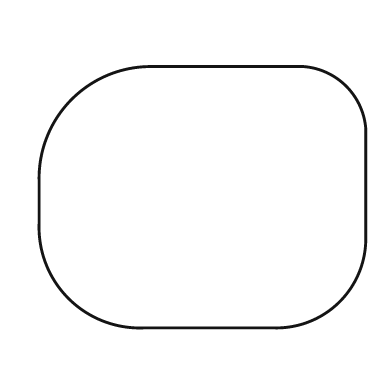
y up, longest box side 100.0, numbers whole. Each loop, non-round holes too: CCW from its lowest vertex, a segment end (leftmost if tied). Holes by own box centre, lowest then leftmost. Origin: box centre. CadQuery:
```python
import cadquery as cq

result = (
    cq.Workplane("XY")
    .moveTo(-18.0, -40.0)
    .lineTo(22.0, -40.0)
    .threePointArc((42.0, -32.0), (50.0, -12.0))
    .lineTo(50.0, 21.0)
    .threePointArc((44.0, 34.0), (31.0, 40.0))
    .lineTo(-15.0, 40.0)
    .threePointArc((-40.0, 30.0), (-50.0, 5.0))
    .lineTo(-50.0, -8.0)
    .threePointArc((-41.0, -31.0), (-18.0, -40.0))
    .close()
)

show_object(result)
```